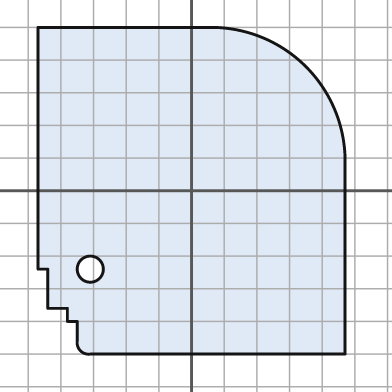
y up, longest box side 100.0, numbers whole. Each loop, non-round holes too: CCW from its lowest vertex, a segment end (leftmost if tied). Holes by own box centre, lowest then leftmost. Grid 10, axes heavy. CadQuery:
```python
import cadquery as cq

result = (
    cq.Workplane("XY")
    .moveTo(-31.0, -50.0)
    .lineTo(47.0, -50.0)
    .lineTo(47.0, 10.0)
    .threePointArc((35.0, 38.0), (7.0, 50.0))
    .lineTo(-47.0, 50.0)
    .lineTo(-47.0, -24.0)
    .lineTo(-44.0, -24.0)
    .lineTo(-44.0, -36.0)
    .lineTo(-38.0, -36.0)
    .lineTo(-38.0, -40.0)
    .lineTo(-35.0, -40.0)
    .lineTo(-35.0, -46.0)
    .threePointArc((-34.0, -49.0), (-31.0, -50.0))
    .close()
    .moveTo(-31.0, -24.0)
    .circle(4.0)
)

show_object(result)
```